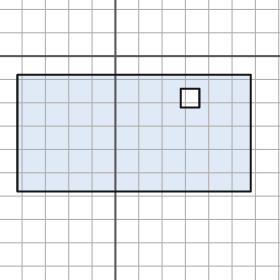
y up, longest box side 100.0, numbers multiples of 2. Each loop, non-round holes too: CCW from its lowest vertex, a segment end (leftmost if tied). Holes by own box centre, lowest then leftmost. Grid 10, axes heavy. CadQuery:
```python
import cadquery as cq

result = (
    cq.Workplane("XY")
    .moveTo(-42.0, -58.0)
    .lineTo(58.0, -58.0)
    .lineTo(58.0, -8.0)
    .lineTo(-42.0, -8.0)
    .close()
    .moveTo(28.0, -22.0)
    .lineTo(36.0, -22.0)
    .lineTo(36.0, -14.0)
    .lineTo(28.0, -14.0)
    .close()
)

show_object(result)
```